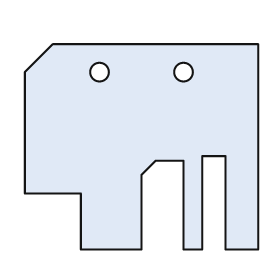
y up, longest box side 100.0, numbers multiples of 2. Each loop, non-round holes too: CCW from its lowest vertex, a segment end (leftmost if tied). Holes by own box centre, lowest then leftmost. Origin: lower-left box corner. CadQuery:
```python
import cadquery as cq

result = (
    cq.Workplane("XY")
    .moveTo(24.0, 0.0)
    .lineTo(50.0, 0.0)
    .lineTo(50.0, 32.0)
    .lineTo(56.0, 38.0)
    .lineTo(68.0, 38.0)
    .lineTo(68.0, 0.0)
    .lineTo(76.0, 0.0)
    .lineTo(76.0, 40.0)
    .lineTo(86.0, 40.0)
    .lineTo(86.0, 0.0)
    .lineTo(100.0, 0.0)
    .lineTo(100.0, 88.0)
    .lineTo(12.0, 88.0)
    .lineTo(0.0, 76.0)
    .lineTo(0.0, 24.0)
    .lineTo(24.0, 24.0)
    .close()
    .moveTo(32.0, 76.0)
    .circle(4.0)
    .moveTo(68.0, 76.0)
    .circle(4.0)
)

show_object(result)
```